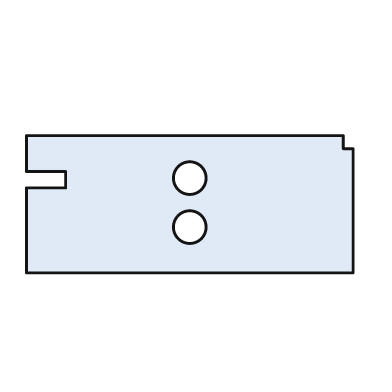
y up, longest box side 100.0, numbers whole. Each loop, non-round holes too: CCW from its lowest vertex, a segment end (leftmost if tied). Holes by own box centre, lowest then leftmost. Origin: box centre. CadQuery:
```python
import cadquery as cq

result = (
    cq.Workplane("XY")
    .moveTo(-50.0, -21.0)
    .lineTo(50.0, -21.0)
    .lineTo(50.0, 17.0)
    .lineTo(47.0, 17.0)
    .lineTo(47.0, 21.0)
    .lineTo(-50.0, 21.0)
    .lineTo(-50.0, 10.0)
    .lineTo(-38.0, 10.0)
    .lineTo(-38.0, 5.0)
    .lineTo(-50.0, 5.0)
    .close()
    .moveTo(0.0, -7.0)
    .circle(5.0)
    .moveTo(0.0, 8.0)
    .circle(5.0)
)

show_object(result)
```